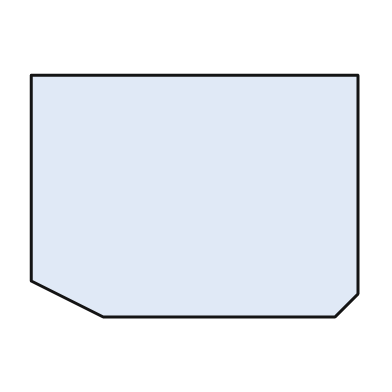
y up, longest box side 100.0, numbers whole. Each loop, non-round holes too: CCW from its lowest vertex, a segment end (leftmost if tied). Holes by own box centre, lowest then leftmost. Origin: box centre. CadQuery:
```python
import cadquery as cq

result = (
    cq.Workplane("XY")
    .moveTo(-28.0, -37.0)
    .lineTo(43.0, -37.0)
    .lineTo(50.0, -30.0)
    .lineTo(50.0, 37.0)
    .lineTo(-50.0, 37.0)
    .lineTo(-50.0, -26.0)
    .close()
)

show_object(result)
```